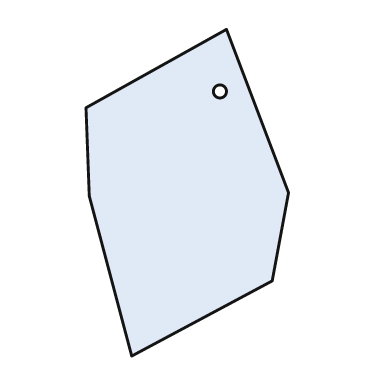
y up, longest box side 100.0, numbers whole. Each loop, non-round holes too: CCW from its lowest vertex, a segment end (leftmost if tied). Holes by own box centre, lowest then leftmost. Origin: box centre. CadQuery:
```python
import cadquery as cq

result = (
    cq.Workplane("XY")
    .moveTo(-17.0, -50.0)
    .lineTo(26.0, -27.0)
    .lineTo(31.0, 0.0)
    .lineTo(12.0, 50.0)
    .lineTo(-31.0, 26.0)
    .lineTo(-30.0, -1.0)
    .close()
    .moveTo(10.0, 31.0)
    .circle(2.0)
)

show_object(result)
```